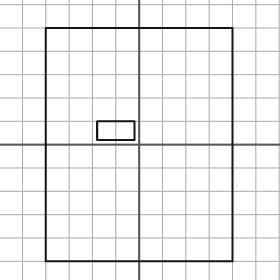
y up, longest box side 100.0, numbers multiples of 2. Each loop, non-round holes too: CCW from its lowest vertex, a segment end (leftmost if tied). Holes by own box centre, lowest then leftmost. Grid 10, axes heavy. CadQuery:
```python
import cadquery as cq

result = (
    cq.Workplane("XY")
    .moveTo(-40.0, -50.0)
    .lineTo(40.0, -50.0)
    .lineTo(40.0, 50.0)
    .lineTo(-40.0, 50.0)
    .close()
    .moveTo(-18.0, 2.0)
    .lineTo(-2.0, 2.0)
    .lineTo(-2.0, 10.0)
    .lineTo(-18.0, 10.0)
    .close()
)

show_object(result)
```